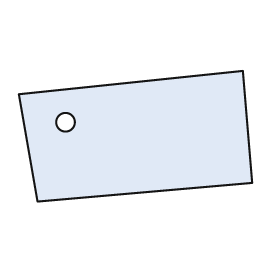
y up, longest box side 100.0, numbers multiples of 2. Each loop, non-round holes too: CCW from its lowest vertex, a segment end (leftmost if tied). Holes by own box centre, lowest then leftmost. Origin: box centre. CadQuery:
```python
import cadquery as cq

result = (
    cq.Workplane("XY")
    .moveTo(-42.0, -28.0)
    .lineTo(50.0, -20.0)
    .lineTo(46.0, 28.0)
    .lineTo(-50.0, 18.0)
    .close()
    .moveTo(-30.0, 6.0)
    .circle(4.0)
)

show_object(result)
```